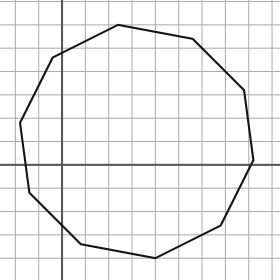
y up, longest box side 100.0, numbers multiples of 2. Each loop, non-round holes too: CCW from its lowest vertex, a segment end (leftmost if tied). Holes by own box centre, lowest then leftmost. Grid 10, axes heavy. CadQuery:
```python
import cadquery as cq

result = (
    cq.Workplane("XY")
    .moveTo(40.0, -40.0)
    .lineTo(68.0, -26.0)
    .lineTo(82.0, 2.0)
    .lineTo(78.0, 32.0)
    .lineTo(56.0, 54.0)
    .lineTo(24.0, 60.0)
    .lineTo(-4.0, 46.0)
    .lineTo(-18.0, 18.0)
    .lineTo(-14.0, -12.0)
    .lineTo(8.0, -34.0)
    .close()
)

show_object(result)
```